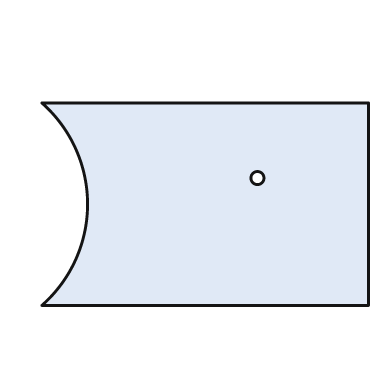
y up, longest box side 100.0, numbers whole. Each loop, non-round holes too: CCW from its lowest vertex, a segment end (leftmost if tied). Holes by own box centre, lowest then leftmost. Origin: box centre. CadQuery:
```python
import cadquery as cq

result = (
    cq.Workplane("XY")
    .moveTo(-50.0, -31.0)
    .lineTo(50.0, -31.0)
    .lineTo(50.0, 31.0)
    .lineTo(-50.0, 31.0)
    .threePointArc((-36.0, 0.0), (-50.0, -31.0))
    .close()
    .moveTo(16.0, 8.0)
    .circle(2.0)
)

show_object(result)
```